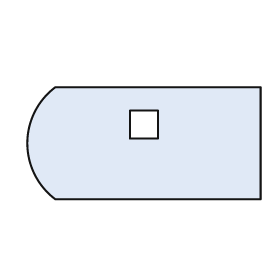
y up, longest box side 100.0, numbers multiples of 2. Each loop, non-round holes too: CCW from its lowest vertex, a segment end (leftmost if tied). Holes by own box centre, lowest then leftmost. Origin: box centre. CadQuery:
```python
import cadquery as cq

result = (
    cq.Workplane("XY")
    .moveTo(-38.0, -24.0)
    .lineTo(50.0, -24.0)
    .lineTo(50.0, 24.0)
    .lineTo(-38.0, 24.0)
    .threePointArc((-50.0, 0.0), (-38.0, -24.0))
    .close()
    .moveTo(-6.0, 2.0)
    .lineTo(6.0, 2.0)
    .lineTo(6.0, 14.0)
    .lineTo(-6.0, 14.0)
    .close()
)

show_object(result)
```